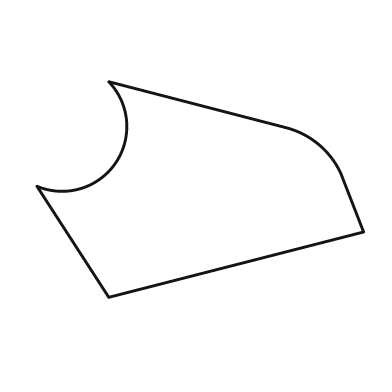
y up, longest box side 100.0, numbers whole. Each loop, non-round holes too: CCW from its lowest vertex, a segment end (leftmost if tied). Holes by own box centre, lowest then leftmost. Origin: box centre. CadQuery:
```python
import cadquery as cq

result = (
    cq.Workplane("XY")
    .moveTo(-28.0, -33.0)
    .lineTo(50.0, -13.0)
    .lineTo(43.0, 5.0)
    .threePointArc((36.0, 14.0), (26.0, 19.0))
    .lineTo(-28.0, 33.0)
    .threePointArc((-26.0, 8.0), (-50.0, 1.0))
    .close()
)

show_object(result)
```